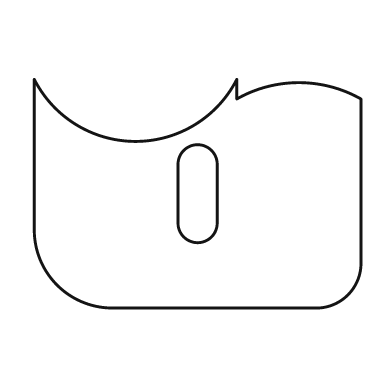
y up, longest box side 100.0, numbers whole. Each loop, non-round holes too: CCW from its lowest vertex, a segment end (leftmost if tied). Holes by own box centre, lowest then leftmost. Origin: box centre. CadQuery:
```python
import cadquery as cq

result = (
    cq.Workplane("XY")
    .moveTo(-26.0, -35.0)
    .lineTo(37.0, -35.0)
    .threePointArc((46.0, -31.0), (50.0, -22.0))
    .lineTo(50.0, 29.0)
    .threePointArc((31.0, 34.0), (12.0, 29.0))
    .lineTo(12.0, 35.0)
    .threePointArc((-19.0, 16.0), (-50.0, 35.0))
    .lineTo(-50.0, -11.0)
    .threePointArc((-43.0, -28.0), (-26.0, -35.0))
    .close()
    .moveTo(-6.0, -9.0)
    .threePointArc((0.0, -15.0), (6.0, -9.0))
    .lineTo(6.0, 9.0)
    .threePointArc((0.0, 15.0), (-6.0, 9.0))
    .close()
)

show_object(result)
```